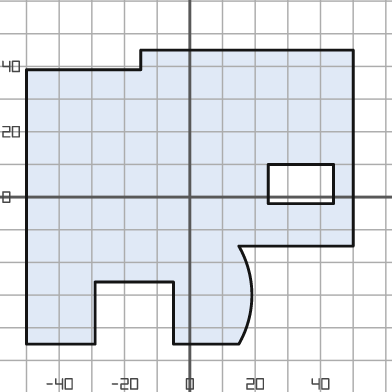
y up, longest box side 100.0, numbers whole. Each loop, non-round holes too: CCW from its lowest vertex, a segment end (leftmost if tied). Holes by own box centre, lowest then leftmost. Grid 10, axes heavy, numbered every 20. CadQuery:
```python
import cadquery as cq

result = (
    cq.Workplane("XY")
    .moveTo(-50.0, -45.0)
    .lineTo(-29.0, -45.0)
    .lineTo(-29.0, -26.0)
    .lineTo(-5.0, -26.0)
    .lineTo(-5.0, -45.0)
    .lineTo(15.0, -45.0)
    .threePointArc((19.0, -30.0), (15.0, -15.0))
    .lineTo(50.0, -15.0)
    .lineTo(50.0, 45.0)
    .lineTo(-15.0, 45.0)
    .lineTo(-15.0, 39.0)
    .lineTo(-50.0, 39.0)
    .close()
    .moveTo(24.0, -2.0)
    .lineTo(44.0, -2.0)
    .lineTo(44.0, 10.0)
    .lineTo(24.0, 10.0)
    .close()
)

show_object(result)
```